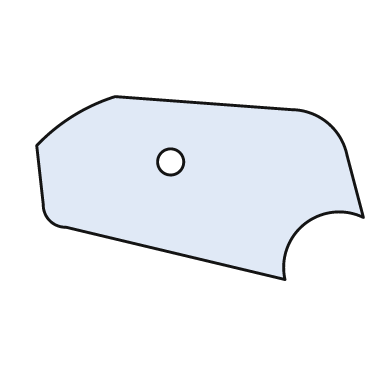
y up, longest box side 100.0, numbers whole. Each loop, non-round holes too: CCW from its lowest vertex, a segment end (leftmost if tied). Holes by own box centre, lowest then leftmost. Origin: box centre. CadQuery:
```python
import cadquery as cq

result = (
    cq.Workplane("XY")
    .moveTo(26.0, -28.0)
    .threePointArc((32.0, -11.0), (50.0, -9.0))
    .lineTo(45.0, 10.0)
    .threePointArc((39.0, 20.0), (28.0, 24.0))
    .lineTo(-26.0, 28.0)
    .threePointArc((-39.0, 22.0), (-50.0, 13.0))
    .lineTo(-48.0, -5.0)
    .threePointArc((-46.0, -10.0), (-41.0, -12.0))
    .close()
    .moveTo(-9.0, 8.0)
    .circle(4.0)
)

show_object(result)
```